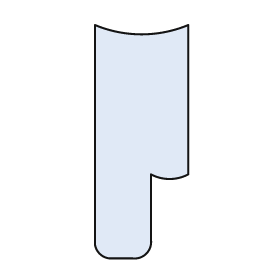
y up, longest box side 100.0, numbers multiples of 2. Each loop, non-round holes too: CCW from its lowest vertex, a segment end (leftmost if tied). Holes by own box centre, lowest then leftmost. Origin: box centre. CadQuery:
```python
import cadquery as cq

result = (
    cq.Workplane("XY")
    .moveTo(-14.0, -50.0)
    .lineTo(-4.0, -50.0)
    .threePointArc((2.0, -48.0), (4.0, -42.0))
    .lineTo(4.0, -14.0)
    .threePointArc((12.0, -16.0), (20.0, -14.0))
    .lineTo(20.0, 50.0)
    .threePointArc((0.0, 46.0), (-20.0, 50.0))
    .lineTo(-20.0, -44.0)
    .threePointArc((-18.0, -48.0), (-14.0, -50.0))
    .close()
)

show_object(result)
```